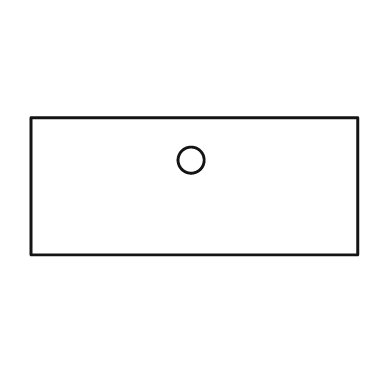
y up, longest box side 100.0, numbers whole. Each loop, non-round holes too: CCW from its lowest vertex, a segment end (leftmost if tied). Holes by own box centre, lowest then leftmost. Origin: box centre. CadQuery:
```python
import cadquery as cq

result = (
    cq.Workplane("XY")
    .moveTo(-50.0, -21.0)
    .lineTo(50.0, -21.0)
    .lineTo(50.0, 21.0)
    .lineTo(-50.0, 21.0)
    .close()
    .moveTo(-1.0, 8.0)
    .circle(4.0)
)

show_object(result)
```